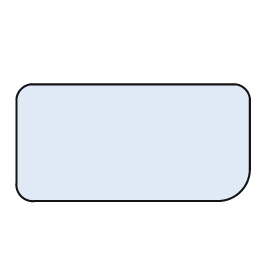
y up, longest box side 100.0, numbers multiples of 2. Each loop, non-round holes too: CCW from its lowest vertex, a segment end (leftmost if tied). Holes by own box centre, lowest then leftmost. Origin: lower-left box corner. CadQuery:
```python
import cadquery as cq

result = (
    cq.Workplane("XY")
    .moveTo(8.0, 0.0)
    .lineTo(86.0, 0.0)
    .threePointArc((96.0, 4.0), (100.0, 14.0))
    .lineTo(100.0, 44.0)
    .threePointArc((98.0, 48.0), (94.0, 50.0))
    .lineTo(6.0, 50.0)
    .threePointArc((2.0, 48.0), (0.0, 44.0))
    .lineTo(0.0, 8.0)
    .threePointArc((2.0, 2.0), (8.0, 0.0))
    .close()
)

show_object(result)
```